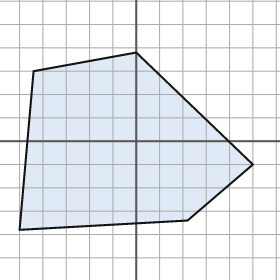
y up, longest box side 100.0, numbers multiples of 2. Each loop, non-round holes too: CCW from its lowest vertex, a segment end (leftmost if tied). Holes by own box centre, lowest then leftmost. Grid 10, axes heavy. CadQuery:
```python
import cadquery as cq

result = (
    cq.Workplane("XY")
    .moveTo(-50.0, -38.0)
    .lineTo(22.0, -34.0)
    .lineTo(50.0, -10.0)
    .lineTo(0.0, 38.0)
    .lineTo(-44.0, 30.0)
    .close()
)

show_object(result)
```